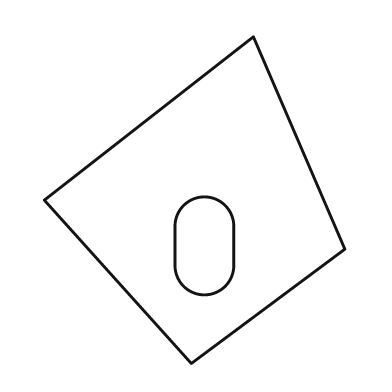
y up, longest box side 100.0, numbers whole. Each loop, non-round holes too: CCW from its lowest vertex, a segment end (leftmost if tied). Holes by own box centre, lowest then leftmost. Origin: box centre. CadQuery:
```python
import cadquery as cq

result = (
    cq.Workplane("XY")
    .moveTo(-1.0, -50.0)
    .lineTo(46.0, -15.0)
    .lineTo(18.0, 50.0)
    .lineTo(-46.0, 0.0)
    .close()
    .moveTo(-6.0, -20.0)
    .threePointArc((3.0, -29.0), (12.0, -20.0))
    .lineTo(12.0, -8.0)
    .threePointArc((3.0, 1.0), (-6.0, -8.0))
    .close()
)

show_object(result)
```